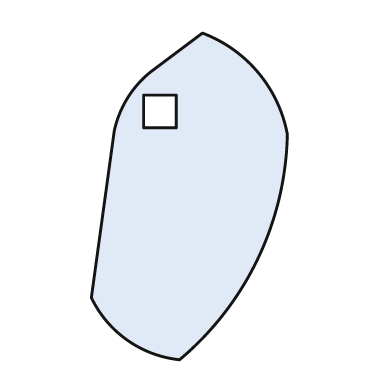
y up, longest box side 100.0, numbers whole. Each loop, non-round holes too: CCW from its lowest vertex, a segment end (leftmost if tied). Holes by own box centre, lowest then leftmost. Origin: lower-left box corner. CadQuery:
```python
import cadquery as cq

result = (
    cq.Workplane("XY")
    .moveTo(27.0, 0.0)
    .threePointArc((51.0, 31.0), (60.0, 69.0))
    .threePointArc((51.0, 88.0), (34.0, 100.0))
    .lineTo(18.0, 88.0)
    .threePointArc((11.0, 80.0), (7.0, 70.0))
    .lineTo(0.0, 19.0)
    .threePointArc((11.0, 6.0), (27.0, 0.0))
    .close()
    .moveTo(16.0, 71.0)
    .lineTo(26.0, 71.0)
    .lineTo(26.0, 81.0)
    .lineTo(16.0, 81.0)
    .close()
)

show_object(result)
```